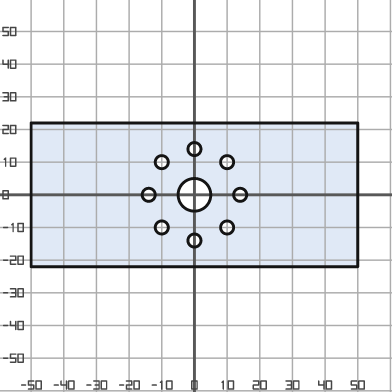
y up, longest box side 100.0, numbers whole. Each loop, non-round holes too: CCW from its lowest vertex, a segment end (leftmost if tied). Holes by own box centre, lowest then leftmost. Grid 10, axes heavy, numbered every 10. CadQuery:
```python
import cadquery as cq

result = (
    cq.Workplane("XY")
    .moveTo(-50.0, -22.0)
    .lineTo(50.0, -22.0)
    .lineTo(50.0, 22.0)
    .lineTo(-50.0, 22.0)
    .close()
    .moveTo(0.0, -14.0)
    .circle(2.0)
    .moveTo(-10.0, -10.0)
    .circle(2.0)
    .moveTo(10.0, -10.0)
    .circle(2.0)
    .moveTo(-14.0, 0.0)
    .circle(2.0)
    .moveTo(0.0, 0.0)
    .circle(5.0)
    .moveTo(14.0, 0.0)
    .circle(2.0)
    .moveTo(-10.0, 10.0)
    .circle(2.0)
    .moveTo(10.0, 10.0)
    .circle(2.0)
    .moveTo(0.0, 14.0)
    .circle(2.0)
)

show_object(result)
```